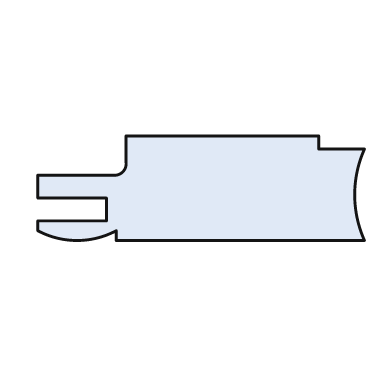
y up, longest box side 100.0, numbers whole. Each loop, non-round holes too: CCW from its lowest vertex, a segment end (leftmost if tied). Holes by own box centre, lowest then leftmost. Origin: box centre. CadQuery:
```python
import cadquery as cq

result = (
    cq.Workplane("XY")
    .moveTo(-26.0, -16.0)
    .lineTo(50.0, -16.0)
    .threePointArc((47.0, -2.0), (50.0, 12.0))
    .lineTo(36.0, 12.0)
    .lineTo(36.0, 16.0)
    .lineTo(-23.0, 16.0)
    .lineTo(-23.0, 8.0)
    .threePointArc((-24.0, 5.0), (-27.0, 4.0))
    .lineTo(-50.0, 4.0)
    .lineTo(-50.0, -3.0)
    .lineTo(-29.0, -3.0)
    .lineTo(-29.0, -10.0)
    .lineTo(-50.0, -10.0)
    .lineTo(-50.0, -13.0)
    .threePointArc((-38.0, -16.0), (-26.0, -13.0))
    .close()
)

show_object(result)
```